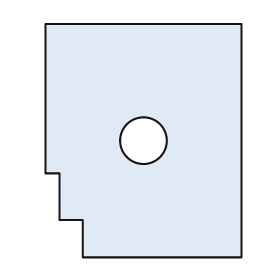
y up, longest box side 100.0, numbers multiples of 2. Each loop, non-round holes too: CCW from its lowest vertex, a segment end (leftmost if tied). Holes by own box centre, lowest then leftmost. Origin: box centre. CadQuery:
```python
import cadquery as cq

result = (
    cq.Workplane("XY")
    .moveTo(-26.0, -50.0)
    .lineTo(42.0, -50.0)
    .lineTo(42.0, 50.0)
    .lineTo(-42.0, 50.0)
    .lineTo(-42.0, -14.0)
    .lineTo(-36.0, -14.0)
    .lineTo(-36.0, -34.0)
    .lineTo(-26.0, -34.0)
    .close()
    .moveTo(0.0, 0.0)
    .circle(10.0)
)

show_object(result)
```